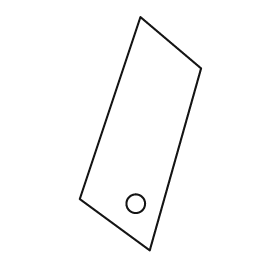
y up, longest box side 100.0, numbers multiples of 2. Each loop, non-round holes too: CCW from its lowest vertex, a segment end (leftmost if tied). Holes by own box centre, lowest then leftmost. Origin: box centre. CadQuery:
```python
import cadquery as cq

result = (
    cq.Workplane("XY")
    .moveTo(4.0, -50.0)
    .lineTo(26.0, 28.0)
    .lineTo(0.0, 50.0)
    .lineTo(-26.0, -28.0)
    .close()
    .moveTo(-2.0, -30.0)
    .circle(4.0)
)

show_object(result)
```